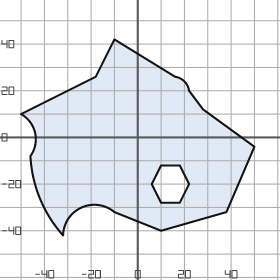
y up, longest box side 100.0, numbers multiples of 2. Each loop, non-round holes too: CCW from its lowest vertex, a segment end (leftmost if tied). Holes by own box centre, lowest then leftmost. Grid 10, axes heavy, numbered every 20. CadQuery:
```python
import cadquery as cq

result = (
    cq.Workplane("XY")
    .moveTo(-32.0, -42.0)
    .threePointArc((-24.0, -30.0), (-10.0, -32.0))
    .lineTo(10.0, -40.0)
    .lineTo(38.0, -32.0)
    .lineTo(50.0, -4.0)
    .lineTo(28.0, 12.0)
    .lineTo(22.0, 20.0)
    .threePointArc((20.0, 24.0), (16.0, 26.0))
    .lineTo(-10.0, 42.0)
    .lineTo(-18.0, 26.0)
    .lineTo(-50.0, 10.0)
    .threePointArc((-44.0, 2.0), (-46.0, -8.0))
    .threePointArc((-42.0, -26.0), (-32.0, -42.0))
    .close()
    .moveTo(10.0, -28.0)
    .lineTo(18.0, -28.0)
    .lineTo(22.0, -20.0)
    .lineTo(18.0, -12.0)
    .lineTo(10.0, -12.0)
    .lineTo(6.0, -20.0)
    .close()
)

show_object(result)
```